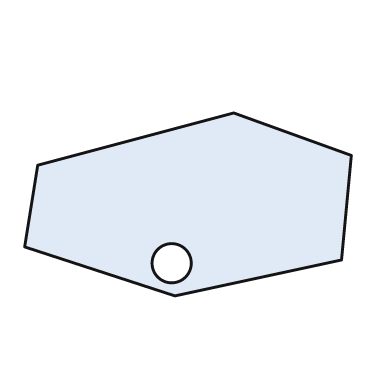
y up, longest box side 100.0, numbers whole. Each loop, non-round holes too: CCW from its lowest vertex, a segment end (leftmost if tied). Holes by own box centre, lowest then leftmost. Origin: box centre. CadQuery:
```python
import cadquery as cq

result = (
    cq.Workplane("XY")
    .moveTo(-4.0, -28.0)
    .lineTo(47.0, -17.0)
    .lineTo(50.0, 15.0)
    .lineTo(14.0, 28.0)
    .lineTo(-46.0, 12.0)
    .lineTo(-50.0, -13.0)
    .close()
    .moveTo(-5.0, -18.0)
    .circle(6.0)
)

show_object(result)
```